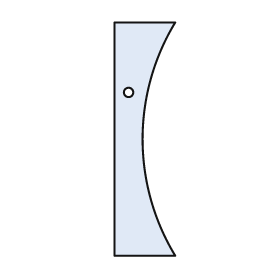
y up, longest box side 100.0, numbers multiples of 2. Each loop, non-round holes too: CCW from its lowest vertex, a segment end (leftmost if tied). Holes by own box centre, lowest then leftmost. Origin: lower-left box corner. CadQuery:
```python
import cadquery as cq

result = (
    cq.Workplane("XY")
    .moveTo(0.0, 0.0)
    .lineTo(26.0, 0.0)
    .threePointArc((12.0, 50.0), (26.0, 100.0))
    .lineTo(0.0, 100.0)
    .close()
    .moveTo(6.0, 70.0)
    .circle(2.0)
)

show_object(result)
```